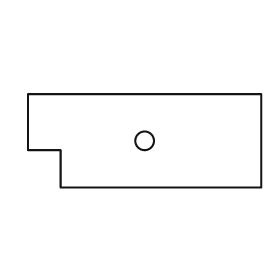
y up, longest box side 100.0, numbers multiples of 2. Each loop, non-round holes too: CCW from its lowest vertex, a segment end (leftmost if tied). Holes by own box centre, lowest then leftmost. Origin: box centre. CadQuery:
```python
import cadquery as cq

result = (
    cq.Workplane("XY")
    .moveTo(-36.0, -20.0)
    .lineTo(50.0, -20.0)
    .lineTo(50.0, 20.0)
    .lineTo(-50.0, 20.0)
    .lineTo(-50.0, -4.0)
    .lineTo(-36.0, -4.0)
    .close()
    .moveTo(0.0, 0.0)
    .circle(4.0)
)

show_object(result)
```